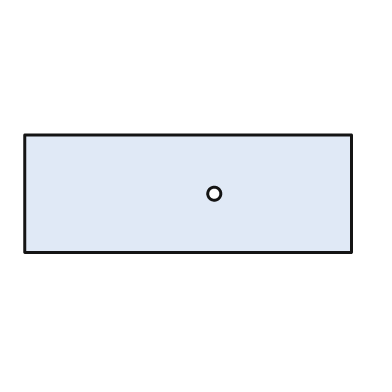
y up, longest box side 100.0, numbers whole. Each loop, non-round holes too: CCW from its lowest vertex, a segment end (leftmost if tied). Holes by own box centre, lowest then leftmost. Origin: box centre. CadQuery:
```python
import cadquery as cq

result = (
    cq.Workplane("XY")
    .moveTo(-50.0, -18.0)
    .lineTo(50.0, -18.0)
    .lineTo(50.0, 18.0)
    .lineTo(-50.0, 18.0)
    .close()
    .moveTo(8.0, 0.0)
    .circle(2.0)
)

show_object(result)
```